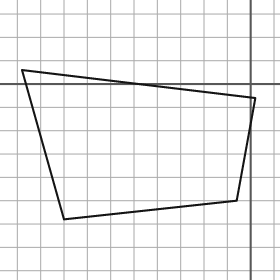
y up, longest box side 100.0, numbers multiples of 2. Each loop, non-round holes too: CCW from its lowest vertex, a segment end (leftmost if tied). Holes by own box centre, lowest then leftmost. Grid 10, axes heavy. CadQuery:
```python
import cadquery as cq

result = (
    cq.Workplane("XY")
    .moveTo(-80.0, -58.0)
    .lineTo(-6.0, -50.0)
    .lineTo(2.0, -6.0)
    .lineTo(-98.0, 6.0)
    .close()
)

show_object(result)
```